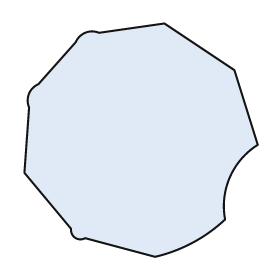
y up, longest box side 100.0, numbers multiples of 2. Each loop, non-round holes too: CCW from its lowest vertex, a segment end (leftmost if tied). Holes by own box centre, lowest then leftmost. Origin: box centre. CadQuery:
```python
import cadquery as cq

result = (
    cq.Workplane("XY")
    .moveTo(6.0, -50.0)
    .threePointArc((22.0, -44.0), (36.0, -34.0))
    .threePointArc((38.0, -16.0), (50.0, -2.0))
    .lineTo(40.0, 30.0)
    .lineTo(10.0, 50.0)
    .lineTo(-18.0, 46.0)
    .threePointArc((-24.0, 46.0), (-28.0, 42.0))
    .lineTo(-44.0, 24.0)
    .threePointArc((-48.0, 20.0), (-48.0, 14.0))
    .lineTo(-50.0, -14.0)
    .lineTo(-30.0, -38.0)
    .threePointArc((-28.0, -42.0), (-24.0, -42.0))
    .close()
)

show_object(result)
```